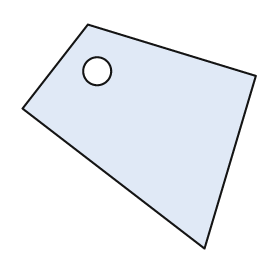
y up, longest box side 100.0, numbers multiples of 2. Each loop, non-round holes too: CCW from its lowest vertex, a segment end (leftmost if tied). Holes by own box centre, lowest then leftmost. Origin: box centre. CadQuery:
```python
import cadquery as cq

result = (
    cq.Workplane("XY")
    .moveTo(28.0, -48.0)
    .lineTo(50.0, 26.0)
    .lineTo(-22.0, 48.0)
    .lineTo(-50.0, 12.0)
    .close()
    .moveTo(-18.0, 28.0)
    .circle(6.0)
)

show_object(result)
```